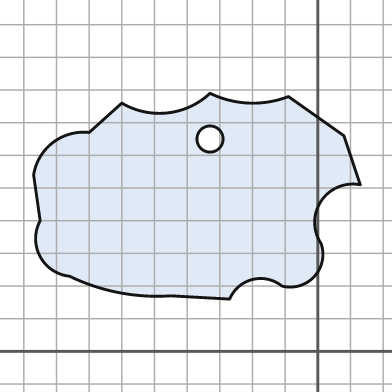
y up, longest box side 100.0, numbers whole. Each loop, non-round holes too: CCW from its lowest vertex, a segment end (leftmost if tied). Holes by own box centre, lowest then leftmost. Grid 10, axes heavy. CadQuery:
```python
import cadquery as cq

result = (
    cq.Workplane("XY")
    .moveTo(-27.0, 16.0)
    .threePointArc((-20.0, 22.0), (-11.0, 20.0))
    .threePointArc((-1.0, 23.0), (1.0, 33.0))
    .threePointArc((1.0, 46.0), (13.0, 51.0))
    .lineTo(8.0, 66.0)
    .lineTo(-9.0, 78.0)
    .threePointArc((-21.0, 76.0), (-33.0, 79.0))
    .threePointArc((-46.0, 73.0), (-60.0, 76.0))
    .lineTo(-70.0, 67.0)
    .threePointArc((-81.0, 64.0), (-87.0, 54.0))
    .lineTo(-85.0, 40.0)
    .threePointArc((-85.0, 29.0), (-76.0, 23.0))
    .threePointArc((-61.0, 18.0), (-45.0, 17.0))
    .close()
    .moveTo(-33.0, 65.0)
    .circle(4.0)
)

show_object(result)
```